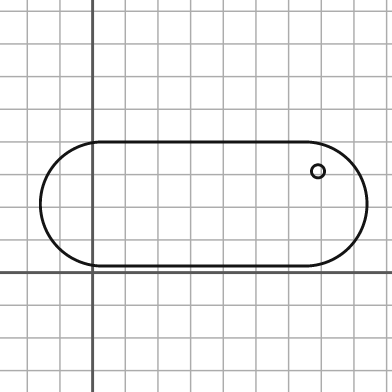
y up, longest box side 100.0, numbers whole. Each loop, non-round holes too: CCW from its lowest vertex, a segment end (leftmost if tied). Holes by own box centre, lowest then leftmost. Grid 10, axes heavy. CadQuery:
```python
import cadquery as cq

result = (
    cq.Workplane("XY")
    .moveTo(3.0, 2.0)
    .lineTo(65.0, 2.0)
    .threePointArc((84.0, 21.0), (65.0, 40.0))
    .lineTo(3.0, 40.0)
    .threePointArc((-16.0, 21.0), (3.0, 2.0))
    .close()
    .moveTo(69.0, 31.0)
    .circle(2.0)
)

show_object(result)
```